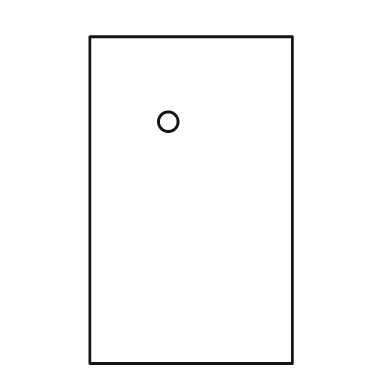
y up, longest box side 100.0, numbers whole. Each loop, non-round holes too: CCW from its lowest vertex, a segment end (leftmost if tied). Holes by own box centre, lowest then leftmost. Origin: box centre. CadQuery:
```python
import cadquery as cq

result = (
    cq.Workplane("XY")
    .moveTo(-31.0, -50.0)
    .lineTo(31.0, -50.0)
    .lineTo(31.0, 50.0)
    .lineTo(-31.0, 50.0)
    .close()
    .moveTo(-7.0, 24.0)
    .circle(3.0)
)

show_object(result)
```